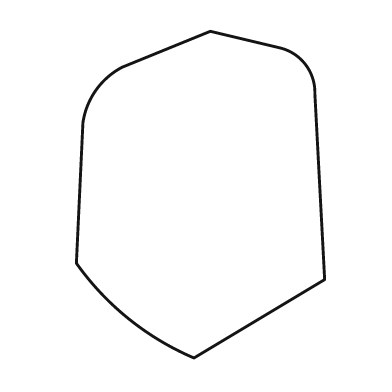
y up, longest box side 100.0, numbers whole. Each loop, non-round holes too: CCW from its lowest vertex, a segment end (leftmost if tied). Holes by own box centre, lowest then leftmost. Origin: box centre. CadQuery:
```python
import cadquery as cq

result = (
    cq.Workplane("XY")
    .moveTo(-2.0, -50.0)
    .lineTo(38.0, -26.0)
    .lineTo(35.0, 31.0)
    .threePointArc((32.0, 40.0), (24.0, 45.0))
    .lineTo(3.0, 50.0)
    .lineTo(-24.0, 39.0)
    .threePointArc((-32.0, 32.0), (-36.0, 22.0))
    .lineTo(-38.0, -21.0)
    .threePointArc((-22.0, -38.0), (-2.0, -50.0))
    .close()
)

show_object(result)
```